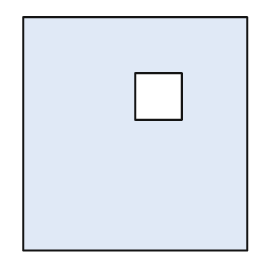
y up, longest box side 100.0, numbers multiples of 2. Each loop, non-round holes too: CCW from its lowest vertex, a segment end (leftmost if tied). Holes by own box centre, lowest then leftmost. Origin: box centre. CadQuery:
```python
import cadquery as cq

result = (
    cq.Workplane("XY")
    .moveTo(-48.0, -50.0)
    .lineTo(48.0, -50.0)
    .lineTo(48.0, 50.0)
    .lineTo(-48.0, 50.0)
    .close()
    .moveTo(0.0, 6.0)
    .lineTo(20.0, 6.0)
    .lineTo(20.0, 26.0)
    .lineTo(0.0, 26.0)
    .close()
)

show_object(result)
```